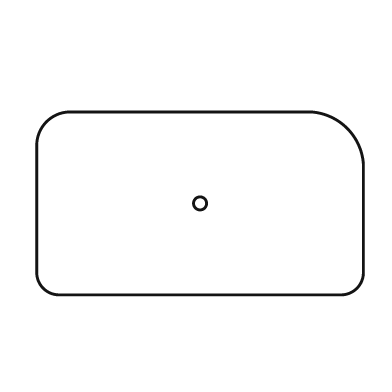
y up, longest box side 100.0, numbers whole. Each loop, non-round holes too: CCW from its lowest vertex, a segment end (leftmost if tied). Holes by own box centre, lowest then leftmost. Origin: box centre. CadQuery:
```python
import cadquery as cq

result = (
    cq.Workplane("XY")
    .moveTo(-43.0, -28.0)
    .lineTo(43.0, -28.0)
    .threePointArc((48.0, -26.0), (50.0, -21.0))
    .lineTo(50.0, 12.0)
    .threePointArc((45.0, 23.0), (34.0, 28.0))
    .lineTo(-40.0, 28.0)
    .threePointArc((-47.0, 25.0), (-50.0, 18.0))
    .lineTo(-50.0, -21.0)
    .threePointArc((-48.0, -26.0), (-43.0, -28.0))
    .close()
    .moveTo(0.0, 0.0)
    .circle(2.0)
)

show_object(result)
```